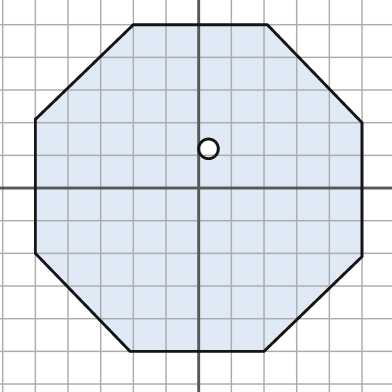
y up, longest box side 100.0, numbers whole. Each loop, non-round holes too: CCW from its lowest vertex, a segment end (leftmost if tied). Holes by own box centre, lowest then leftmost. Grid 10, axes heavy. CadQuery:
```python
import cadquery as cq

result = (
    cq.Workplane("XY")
    .moveTo(-21.0, -50.0)
    .lineTo(20.0, -50.0)
    .lineTo(50.0, -21.0)
    .lineTo(50.0, 20.0)
    .lineTo(21.0, 50.0)
    .lineTo(-20.0, 50.0)
    .lineTo(-50.0, 21.0)
    .lineTo(-50.0, -20.0)
    .close()
    .moveTo(3.0, 12.0)
    .circle(3.0)
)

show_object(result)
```